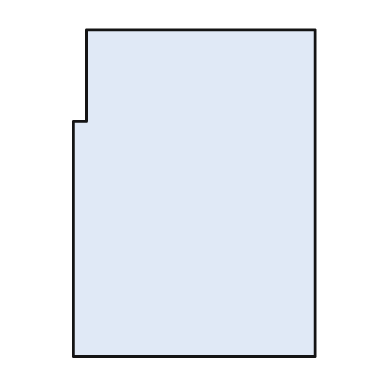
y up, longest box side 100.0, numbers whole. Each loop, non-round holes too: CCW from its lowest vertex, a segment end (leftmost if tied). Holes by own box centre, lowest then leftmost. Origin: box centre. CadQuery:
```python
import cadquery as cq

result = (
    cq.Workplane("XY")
    .moveTo(-37.0, -50.0)
    .lineTo(37.0, -50.0)
    .lineTo(37.0, 50.0)
    .lineTo(-33.0, 50.0)
    .lineTo(-33.0, 22.0)
    .lineTo(-37.0, 22.0)
    .close()
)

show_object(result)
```